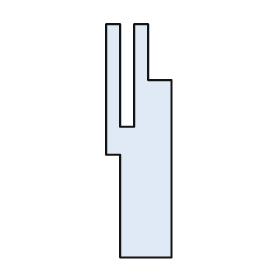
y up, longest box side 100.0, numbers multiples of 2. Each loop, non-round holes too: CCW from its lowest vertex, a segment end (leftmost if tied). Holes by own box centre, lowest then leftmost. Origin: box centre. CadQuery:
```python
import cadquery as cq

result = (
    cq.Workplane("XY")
    .moveTo(-8.0, -50.0)
    .lineTo(14.0, -50.0)
    .lineTo(14.0, 26.0)
    .lineTo(4.0, 26.0)
    .lineTo(4.0, 50.0)
    .lineTo(-2.0, 50.0)
    .lineTo(-2.0, 6.0)
    .lineTo(-8.0, 6.0)
    .lineTo(-8.0, 50.0)
    .lineTo(-14.0, 50.0)
    .lineTo(-14.0, -6.0)
    .lineTo(-8.0, -6.0)
    .close()
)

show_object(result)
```